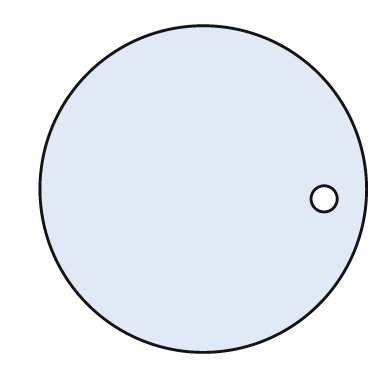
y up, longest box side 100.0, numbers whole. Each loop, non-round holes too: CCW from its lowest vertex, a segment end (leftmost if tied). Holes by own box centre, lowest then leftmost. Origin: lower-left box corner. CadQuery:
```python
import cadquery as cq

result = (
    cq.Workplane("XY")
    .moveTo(50.0, 50.0)
    .circle(50.0)
    .moveTo(87.0, 47.0)
    .circle(4.0)
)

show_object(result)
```